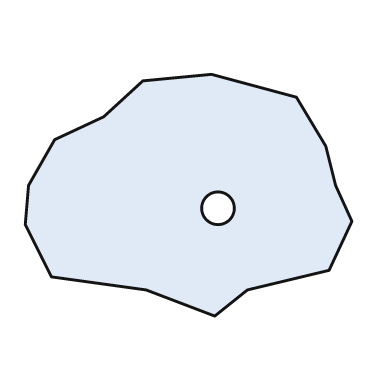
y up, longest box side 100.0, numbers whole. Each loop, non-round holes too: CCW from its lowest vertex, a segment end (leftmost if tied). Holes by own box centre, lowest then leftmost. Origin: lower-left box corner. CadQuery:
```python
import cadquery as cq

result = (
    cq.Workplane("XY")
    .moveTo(58.0, 0.0)
    .lineTo(68.0, 8.0)
    .lineTo(93.0, 14.0)
    .lineTo(100.0, 29.0)
    .lineTo(95.0, 40.0)
    .lineTo(92.0, 52.0)
    .lineTo(83.0, 67.0)
    .lineTo(57.0, 74.0)
    .lineTo(36.0, 72.0)
    .lineTo(24.0, 61.0)
    .lineTo(9.0, 54.0)
    .lineTo(1.0, 40.0)
    .lineTo(0.0, 28.0)
    .lineTo(8.0, 12.0)
    .lineTo(37.0, 8.0)
    .close()
    .moveTo(59.0, 33.0)
    .circle(5.0)
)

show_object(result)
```